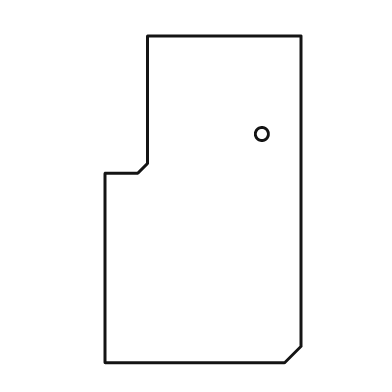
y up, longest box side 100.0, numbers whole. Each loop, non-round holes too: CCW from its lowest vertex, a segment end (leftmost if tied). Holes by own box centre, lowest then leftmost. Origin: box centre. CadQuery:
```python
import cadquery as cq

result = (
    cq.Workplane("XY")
    .moveTo(-30.0, -50.0)
    .lineTo(25.0, -50.0)
    .lineTo(30.0, -45.0)
    .lineTo(30.0, 50.0)
    .lineTo(-17.0, 50.0)
    .lineTo(-17.0, 11.0)
    .lineTo(-20.0, 8.0)
    .lineTo(-30.0, 8.0)
    .close()
    .moveTo(18.0, 20.0)
    .circle(2.0)
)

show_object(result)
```